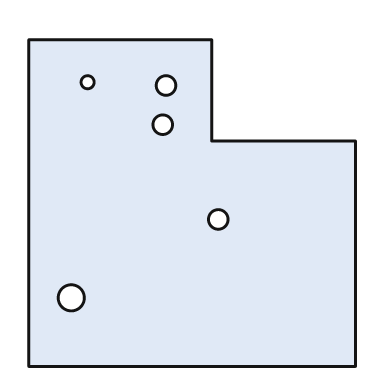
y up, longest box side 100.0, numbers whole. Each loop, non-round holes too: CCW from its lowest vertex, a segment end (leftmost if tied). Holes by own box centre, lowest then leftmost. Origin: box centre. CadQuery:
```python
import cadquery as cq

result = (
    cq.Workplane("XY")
    .moveTo(-50.0, -50.0)
    .lineTo(50.0, -50.0)
    .lineTo(50.0, 19.0)
    .lineTo(6.0, 19.0)
    .lineTo(6.0, 50.0)
    .lineTo(-50.0, 50.0)
    .close()
    .moveTo(-37.0, -29.0)
    .circle(4.0)
    .moveTo(8.0, -5.0)
    .circle(3.0)
    .moveTo(-9.0, 24.0)
    .circle(3.0)
    .moveTo(-8.0, 36.0)
    .circle(3.0)
    .moveTo(-32.0, 37.0)
    .circle(2.0)
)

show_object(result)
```